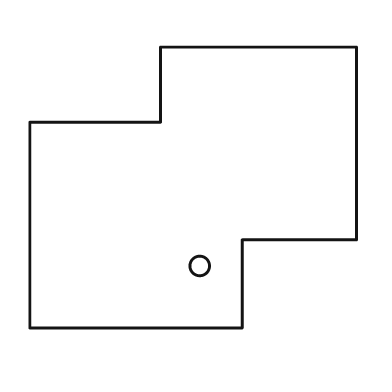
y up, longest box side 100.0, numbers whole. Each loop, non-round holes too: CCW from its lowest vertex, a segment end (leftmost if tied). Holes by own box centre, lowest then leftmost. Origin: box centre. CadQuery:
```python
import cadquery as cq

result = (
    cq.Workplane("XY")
    .moveTo(-50.0, -43.0)
    .lineTo(15.0, -43.0)
    .lineTo(15.0, -16.0)
    .lineTo(50.0, -16.0)
    .lineTo(50.0, 43.0)
    .lineTo(-10.0, 43.0)
    .lineTo(-10.0, 20.0)
    .lineTo(-50.0, 20.0)
    .close()
    .moveTo(2.0, -24.0)
    .circle(3.0)
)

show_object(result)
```